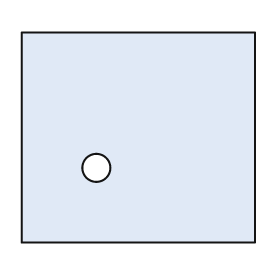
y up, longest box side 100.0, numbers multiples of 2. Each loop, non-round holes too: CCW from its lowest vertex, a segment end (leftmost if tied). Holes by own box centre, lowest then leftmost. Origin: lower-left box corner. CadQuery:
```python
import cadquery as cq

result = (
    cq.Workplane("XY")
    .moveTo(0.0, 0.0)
    .lineTo(100.0, 0.0)
    .lineTo(100.0, 90.0)
    .lineTo(0.0, 90.0)
    .close()
    .moveTo(32.0, 32.0)
    .circle(6.0)
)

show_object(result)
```